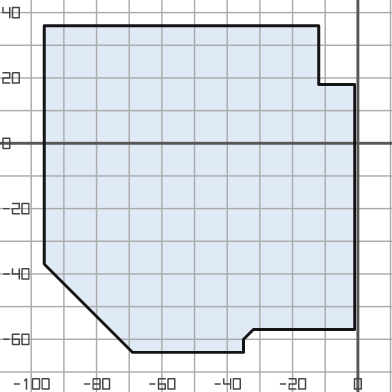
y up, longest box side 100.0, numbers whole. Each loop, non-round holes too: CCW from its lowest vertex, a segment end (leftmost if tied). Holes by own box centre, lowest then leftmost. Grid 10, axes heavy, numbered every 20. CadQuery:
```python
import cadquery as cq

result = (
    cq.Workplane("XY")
    .moveTo(-69.0, -64.0)
    .lineTo(-35.0, -64.0)
    .lineTo(-35.0, -60.0)
    .lineTo(-32.0, -57.0)
    .lineTo(-1.0, -57.0)
    .lineTo(-1.0, 18.0)
    .lineTo(-12.0, 18.0)
    .lineTo(-12.0, 36.0)
    .lineTo(-96.0, 36.0)
    .lineTo(-96.0, -37.0)
    .close()
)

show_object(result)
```